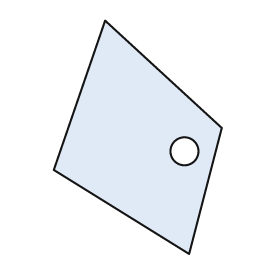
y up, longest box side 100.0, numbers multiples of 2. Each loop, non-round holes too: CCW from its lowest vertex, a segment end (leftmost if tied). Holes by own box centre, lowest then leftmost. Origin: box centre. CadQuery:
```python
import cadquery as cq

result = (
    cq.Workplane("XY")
    .moveTo(22.0, -50.0)
    .lineTo(36.0, 4.0)
    .lineTo(-14.0, 50.0)
    .lineTo(-36.0, -14.0)
    .close()
    .moveTo(20.0, -6.0)
    .circle(6.0)
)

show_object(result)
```